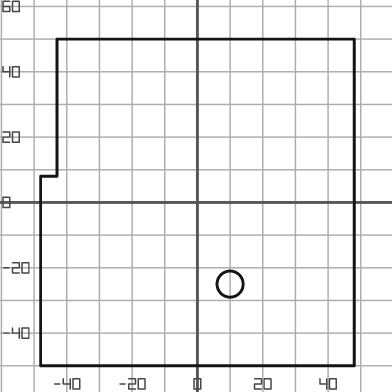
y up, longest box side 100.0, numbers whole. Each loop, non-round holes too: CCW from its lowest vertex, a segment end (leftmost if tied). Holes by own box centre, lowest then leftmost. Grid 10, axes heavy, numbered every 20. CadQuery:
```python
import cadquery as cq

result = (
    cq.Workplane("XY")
    .moveTo(-48.0, -50.0)
    .lineTo(48.0, -50.0)
    .lineTo(48.0, 50.0)
    .lineTo(-43.0, 50.0)
    .lineTo(-43.0, 8.0)
    .lineTo(-48.0, 8.0)
    .close()
    .moveTo(10.0, -25.0)
    .circle(4.0)
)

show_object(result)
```